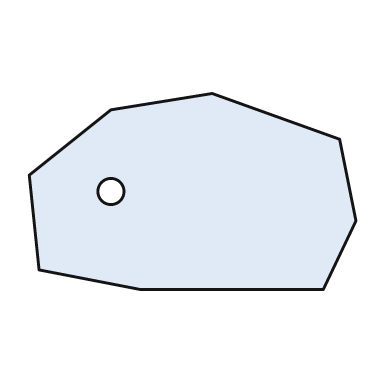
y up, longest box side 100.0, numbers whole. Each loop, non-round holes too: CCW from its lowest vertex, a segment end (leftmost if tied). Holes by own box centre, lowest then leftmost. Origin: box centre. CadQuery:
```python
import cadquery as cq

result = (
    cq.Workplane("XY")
    .moveTo(-16.0, -30.0)
    .lineTo(40.0, -30.0)
    .lineTo(50.0, -9.0)
    .lineTo(45.0, 16.0)
    .lineTo(6.0, 30.0)
    .lineTo(-25.0, 25.0)
    .lineTo(-50.0, 5.0)
    .lineTo(-47.0, -24.0)
    .close()
    .moveTo(-25.0, 0.0)
    .circle(4.0)
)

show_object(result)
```